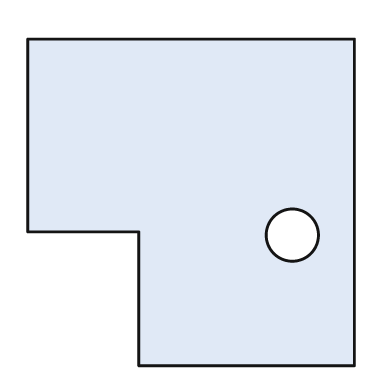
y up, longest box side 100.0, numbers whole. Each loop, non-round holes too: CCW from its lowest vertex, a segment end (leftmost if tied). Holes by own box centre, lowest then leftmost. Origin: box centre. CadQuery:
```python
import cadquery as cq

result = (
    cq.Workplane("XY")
    .moveTo(-16.0, -50.0)
    .lineTo(50.0, -50.0)
    .lineTo(50.0, 50.0)
    .lineTo(-50.0, 50.0)
    .lineTo(-50.0, -9.0)
    .lineTo(-16.0, -9.0)
    .close()
    .moveTo(31.0, -10.0)
    .circle(8.0)
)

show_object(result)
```